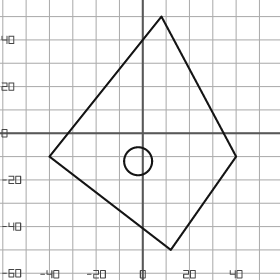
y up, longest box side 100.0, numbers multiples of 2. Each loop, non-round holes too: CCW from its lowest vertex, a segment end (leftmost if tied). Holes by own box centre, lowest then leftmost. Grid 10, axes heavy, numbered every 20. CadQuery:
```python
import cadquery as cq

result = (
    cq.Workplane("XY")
    .moveTo(12.0, -50.0)
    .lineTo(40.0, -10.0)
    .lineTo(8.0, 50.0)
    .lineTo(-40.0, -10.0)
    .close()
    .moveTo(-2.0, -12.0)
    .circle(6.0)
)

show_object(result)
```